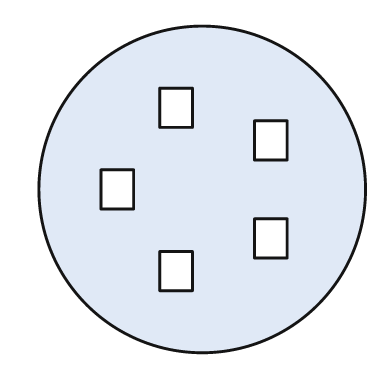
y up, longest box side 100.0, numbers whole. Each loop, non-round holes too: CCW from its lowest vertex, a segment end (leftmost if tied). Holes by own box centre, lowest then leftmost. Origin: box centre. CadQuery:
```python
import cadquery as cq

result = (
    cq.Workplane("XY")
    .moveTo(0.0, 0.0)
    .circle(50.0)
    .moveTo(-13.0, -31.0)
    .lineTo(-3.0, -31.0)
    .lineTo(-3.0, -19.0)
    .lineTo(-13.0, -19.0)
    .close()
    .moveTo(16.0, -21.0)
    .lineTo(26.0, -21.0)
    .lineTo(26.0, -9.0)
    .lineTo(16.0, -9.0)
    .close()
    .moveTo(-31.0, -6.0)
    .lineTo(-21.0, -6.0)
    .lineTo(-21.0, 6.0)
    .lineTo(-31.0, 6.0)
    .close()
    .moveTo(16.0, 9.0)
    .lineTo(26.0, 9.0)
    .lineTo(26.0, 21.0)
    .lineTo(16.0, 21.0)
    .close()
    .moveTo(-13.0, 19.0)
    .lineTo(-3.0, 19.0)
    .lineTo(-3.0, 31.0)
    .lineTo(-13.0, 31.0)
    .close()
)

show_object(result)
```